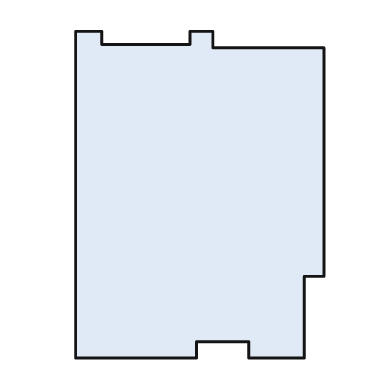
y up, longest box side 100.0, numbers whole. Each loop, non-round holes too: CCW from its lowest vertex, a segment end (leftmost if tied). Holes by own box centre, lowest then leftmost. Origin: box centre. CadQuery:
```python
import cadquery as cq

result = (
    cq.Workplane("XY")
    .moveTo(-38.0, -50.0)
    .lineTo(-1.0, -50.0)
    .lineTo(-1.0, -45.0)
    .lineTo(15.0, -45.0)
    .lineTo(15.0, -50.0)
    .lineTo(32.0, -50.0)
    .lineTo(32.0, -25.0)
    .lineTo(38.0, -25.0)
    .lineTo(38.0, 45.0)
    .lineTo(4.0, 45.0)
    .lineTo(4.0, 50.0)
    .lineTo(-3.0, 50.0)
    .lineTo(-3.0, 46.0)
    .lineTo(-30.0, 46.0)
    .lineTo(-30.0, 50.0)
    .lineTo(-38.0, 50.0)
    .close()
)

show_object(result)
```